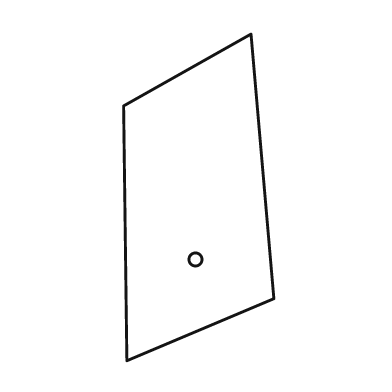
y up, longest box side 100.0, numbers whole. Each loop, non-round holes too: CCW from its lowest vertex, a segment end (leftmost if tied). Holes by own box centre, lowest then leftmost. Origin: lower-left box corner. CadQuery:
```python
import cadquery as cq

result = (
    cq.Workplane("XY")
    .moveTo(1.0, 0.0)
    .lineTo(46.0, 19.0)
    .lineTo(39.0, 100.0)
    .lineTo(0.0, 78.0)
    .close()
    .moveTo(22.0, 31.0)
    .circle(2.0)
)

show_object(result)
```